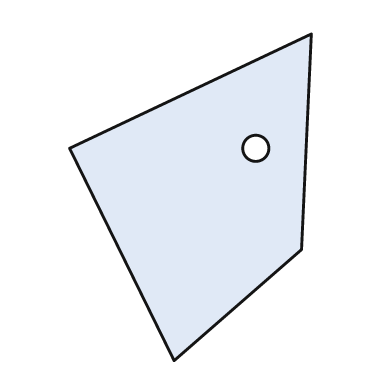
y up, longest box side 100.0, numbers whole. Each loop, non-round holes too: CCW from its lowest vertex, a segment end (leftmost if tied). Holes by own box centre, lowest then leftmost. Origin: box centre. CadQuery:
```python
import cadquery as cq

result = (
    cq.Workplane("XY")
    .moveTo(-5.0, -50.0)
    .lineTo(34.0, -16.0)
    .lineTo(37.0, 50.0)
    .lineTo(-37.0, 15.0)
    .close()
    .moveTo(20.0, 15.0)
    .circle(4.0)
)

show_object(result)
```